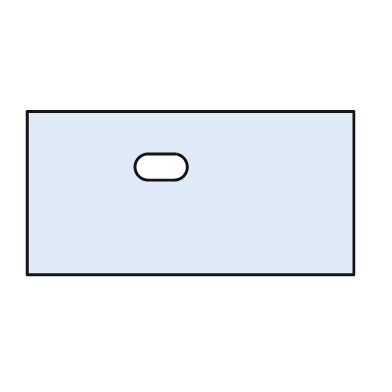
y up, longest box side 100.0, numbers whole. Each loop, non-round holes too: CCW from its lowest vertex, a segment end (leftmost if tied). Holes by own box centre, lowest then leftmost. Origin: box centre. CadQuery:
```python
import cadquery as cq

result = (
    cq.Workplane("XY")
    .moveTo(-50.0, -25.0)
    .lineTo(50.0, -25.0)
    .lineTo(50.0, 25.0)
    .lineTo(-50.0, 25.0)
    .close()
    .moveTo(-13.0, 4.0)
    .lineTo(-5.0, 4.0)
    .threePointArc((-1.0, 8.0), (-5.0, 12.0))
    .lineTo(-13.0, 12.0)
    .threePointArc((-17.0, 8.0), (-13.0, 4.0))
    .close()
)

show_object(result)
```